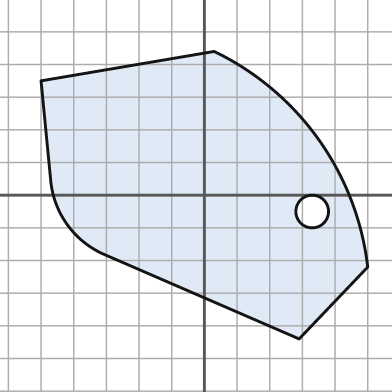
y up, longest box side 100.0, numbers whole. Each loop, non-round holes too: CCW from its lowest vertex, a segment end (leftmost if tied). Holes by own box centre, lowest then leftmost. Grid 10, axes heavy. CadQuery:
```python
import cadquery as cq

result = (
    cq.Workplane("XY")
    .moveTo(29.0, -44.0)
    .lineTo(50.0, -22.0)
    .threePointArc((35.0, 17.0), (3.0, 44.0))
    .lineTo(-50.0, 35.0)
    .lineTo(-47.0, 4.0)
    .threePointArc((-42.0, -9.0), (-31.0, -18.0))
    .close()
    .moveTo(33.0, -5.0)
    .circle(5.0)
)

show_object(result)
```